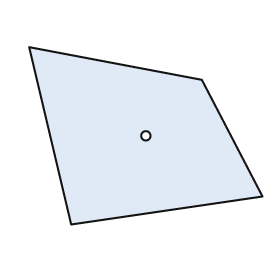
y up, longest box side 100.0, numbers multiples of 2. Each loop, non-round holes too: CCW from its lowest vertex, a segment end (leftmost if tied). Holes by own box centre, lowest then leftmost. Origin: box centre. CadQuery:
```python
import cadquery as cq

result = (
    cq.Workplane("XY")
    .moveTo(-32.0, -38.0)
    .lineTo(50.0, -26.0)
    .lineTo(24.0, 24.0)
    .lineTo(-50.0, 38.0)
    .close()
    .moveTo(0.0, 0.0)
    .circle(2.0)
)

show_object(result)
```